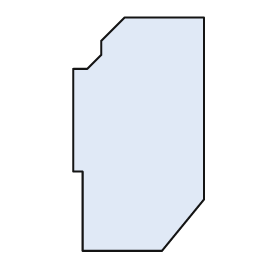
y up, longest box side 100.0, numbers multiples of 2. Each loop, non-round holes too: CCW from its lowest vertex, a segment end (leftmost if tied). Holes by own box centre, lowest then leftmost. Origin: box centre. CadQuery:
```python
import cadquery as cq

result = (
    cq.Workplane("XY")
    .moveTo(-24.0, -50.0)
    .lineTo(10.0, -50.0)
    .lineTo(28.0, -28.0)
    .lineTo(28.0, 50.0)
    .lineTo(-6.0, 50.0)
    .lineTo(-16.0, 40.0)
    .lineTo(-16.0, 34.0)
    .lineTo(-22.0, 28.0)
    .lineTo(-28.0, 28.0)
    .lineTo(-28.0, -16.0)
    .lineTo(-24.0, -16.0)
    .close()
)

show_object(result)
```